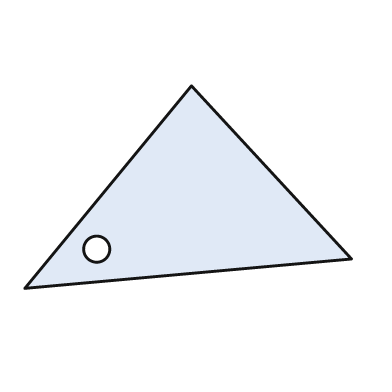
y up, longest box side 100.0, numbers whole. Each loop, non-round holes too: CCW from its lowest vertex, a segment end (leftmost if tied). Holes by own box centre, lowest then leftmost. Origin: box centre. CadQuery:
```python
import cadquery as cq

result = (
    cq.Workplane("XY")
    .moveTo(-50.0, -31.0)
    .lineTo(50.0, -22.0)
    .lineTo(1.0, 31.0)
    .close()
    .moveTo(-28.0, -19.0)
    .circle(4.0)
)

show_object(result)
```